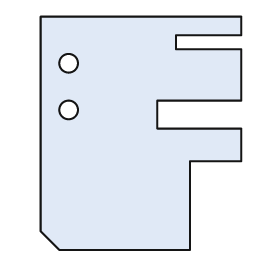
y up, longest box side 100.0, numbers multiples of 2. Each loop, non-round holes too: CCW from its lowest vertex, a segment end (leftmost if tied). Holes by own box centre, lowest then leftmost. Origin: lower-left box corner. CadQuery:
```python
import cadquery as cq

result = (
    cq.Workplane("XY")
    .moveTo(8.0, 0.0)
    .lineTo(64.0, 0.0)
    .lineTo(64.0, 38.0)
    .lineTo(86.0, 38.0)
    .lineTo(86.0, 52.0)
    .lineTo(50.0, 52.0)
    .lineTo(50.0, 64.0)
    .lineTo(86.0, 64.0)
    .lineTo(86.0, 86.0)
    .lineTo(58.0, 86.0)
    .lineTo(58.0, 92.0)
    .lineTo(86.0, 92.0)
    .lineTo(86.0, 100.0)
    .lineTo(0.0, 100.0)
    .lineTo(0.0, 8.0)
    .close()
    .moveTo(12.0, 60.0)
    .circle(4.0)
    .moveTo(12.0, 80.0)
    .circle(4.0)
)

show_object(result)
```